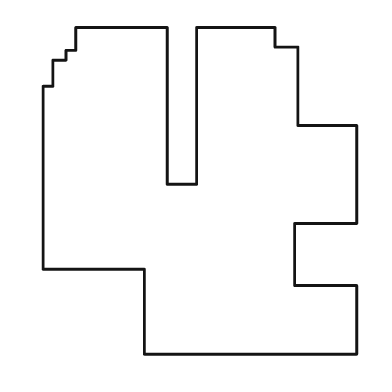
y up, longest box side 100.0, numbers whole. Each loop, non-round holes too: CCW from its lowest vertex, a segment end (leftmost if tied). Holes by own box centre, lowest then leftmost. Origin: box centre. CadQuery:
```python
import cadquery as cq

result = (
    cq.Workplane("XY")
    .moveTo(-17.0, -50.0)
    .lineTo(48.0, -50.0)
    .lineTo(48.0, -29.0)
    .lineTo(29.0, -29.0)
    .lineTo(29.0, -10.0)
    .lineTo(48.0, -10.0)
    .lineTo(48.0, 20.0)
    .lineTo(30.0, 20.0)
    .lineTo(30.0, 44.0)
    .lineTo(23.0, 44.0)
    .lineTo(23.0, 50.0)
    .lineTo(-1.0, 50.0)
    .lineTo(-1.0, 2.0)
    .lineTo(-10.0, 2.0)
    .lineTo(-10.0, 50.0)
    .lineTo(-38.0, 50.0)
    .lineTo(-38.0, 43.0)
    .lineTo(-41.0, 43.0)
    .lineTo(-41.0, 40.0)
    .lineTo(-45.0, 40.0)
    .lineTo(-45.0, 32.0)
    .lineTo(-48.0, 32.0)
    .lineTo(-48.0, -24.0)
    .lineTo(-17.0, -24.0)
    .close()
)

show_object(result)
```